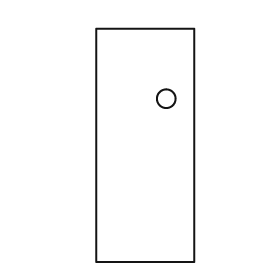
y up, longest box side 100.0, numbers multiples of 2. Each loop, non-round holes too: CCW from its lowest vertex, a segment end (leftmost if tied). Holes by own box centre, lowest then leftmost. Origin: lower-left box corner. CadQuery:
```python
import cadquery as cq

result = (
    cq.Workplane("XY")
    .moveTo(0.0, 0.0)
    .lineTo(42.0, 0.0)
    .lineTo(42.0, 100.0)
    .lineTo(0.0, 100.0)
    .close()
    .moveTo(30.0, 70.0)
    .circle(4.0)
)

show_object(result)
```